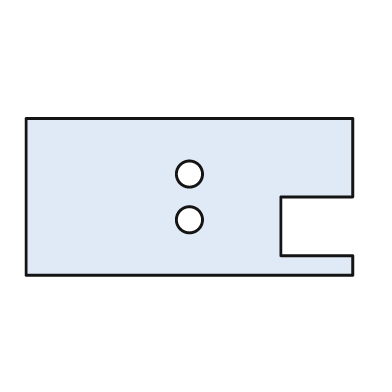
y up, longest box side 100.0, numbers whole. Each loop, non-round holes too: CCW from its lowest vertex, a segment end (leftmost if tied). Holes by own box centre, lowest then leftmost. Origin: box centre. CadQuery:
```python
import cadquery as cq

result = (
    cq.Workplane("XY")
    .moveTo(-50.0, -24.0)
    .lineTo(50.0, -24.0)
    .lineTo(50.0, -18.0)
    .lineTo(28.0, -18.0)
    .lineTo(28.0, 0.0)
    .lineTo(50.0, 0.0)
    .lineTo(50.0, 24.0)
    .lineTo(-50.0, 24.0)
    .close()
    .moveTo(0.0, -7.0)
    .circle(4.0)
    .moveTo(0.0, 7.0)
    .circle(4.0)
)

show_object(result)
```